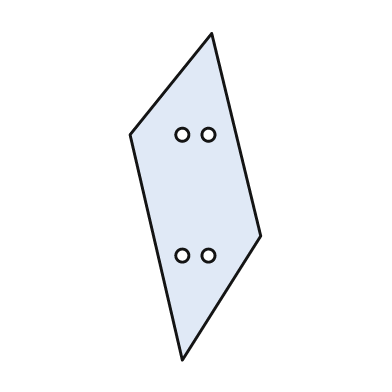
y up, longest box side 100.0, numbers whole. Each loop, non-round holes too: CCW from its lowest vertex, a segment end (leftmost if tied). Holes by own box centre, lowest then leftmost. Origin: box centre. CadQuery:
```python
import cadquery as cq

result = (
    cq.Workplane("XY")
    .moveTo(-4.0, -50.0)
    .lineTo(20.0, -12.0)
    .lineTo(5.0, 50.0)
    .lineTo(-20.0, 19.0)
    .close()
    .moveTo(-4.0, -18.0)
    .circle(2.0)
    .moveTo(4.0, -18.0)
    .circle(2.0)
    .moveTo(-4.0, 19.0)
    .circle(2.0)
    .moveTo(4.0, 19.0)
    .circle(2.0)
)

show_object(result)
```